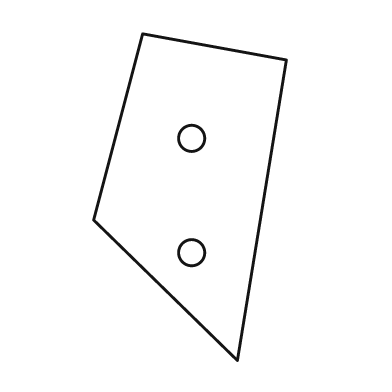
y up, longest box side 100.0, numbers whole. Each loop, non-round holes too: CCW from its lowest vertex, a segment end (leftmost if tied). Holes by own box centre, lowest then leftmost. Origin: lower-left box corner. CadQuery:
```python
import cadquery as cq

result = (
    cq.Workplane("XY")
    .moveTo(44.0, 0.0)
    .lineTo(59.0, 92.0)
    .lineTo(15.0, 100.0)
    .lineTo(0.0, 43.0)
    .close()
    .moveTo(30.0, 33.0)
    .circle(4.0)
    .moveTo(30.0, 68.0)
    .circle(4.0)
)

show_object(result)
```